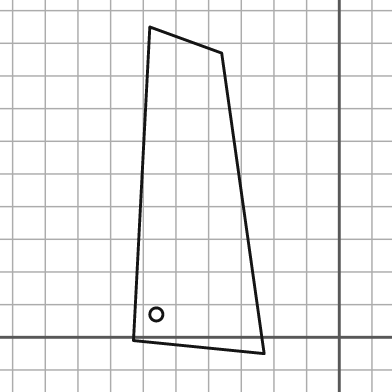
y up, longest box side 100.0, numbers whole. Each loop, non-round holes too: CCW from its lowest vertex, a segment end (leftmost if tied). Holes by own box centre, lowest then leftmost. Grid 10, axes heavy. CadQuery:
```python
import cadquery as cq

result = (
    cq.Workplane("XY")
    .moveTo(-23.0, -5.0)
    .lineTo(-36.0, 87.0)
    .lineTo(-58.0, 95.0)
    .lineTo(-63.0, -1.0)
    .close()
    .moveTo(-56.0, 7.0)
    .circle(2.0)
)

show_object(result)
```